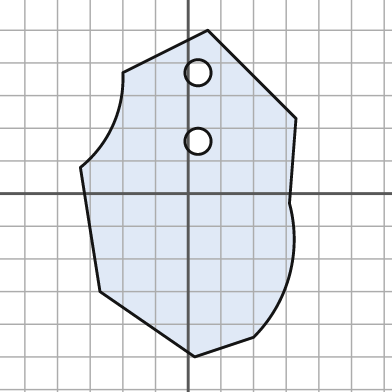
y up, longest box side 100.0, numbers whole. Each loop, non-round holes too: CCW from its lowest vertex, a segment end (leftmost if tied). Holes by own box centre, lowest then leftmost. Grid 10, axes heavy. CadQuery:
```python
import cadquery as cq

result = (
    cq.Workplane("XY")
    .moveTo(2.0, -50.0)
    .lineTo(20.0, -44.0)
    .threePointArc((31.0, -25.0), (31.0, -3.0))
    .lineTo(33.0, 23.0)
    .lineTo(6.0, 50.0)
    .lineTo(-20.0, 37.0)
    .threePointArc((-23.0, 21.0), (-33.0, 8.0))
    .lineTo(-27.0, -30.0)
    .close()
    .moveTo(3.0, 16.0)
    .circle(4.0)
    .moveTo(3.0, 37.0)
    .circle(4.0)
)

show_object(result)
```